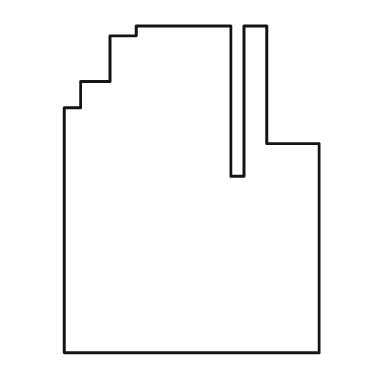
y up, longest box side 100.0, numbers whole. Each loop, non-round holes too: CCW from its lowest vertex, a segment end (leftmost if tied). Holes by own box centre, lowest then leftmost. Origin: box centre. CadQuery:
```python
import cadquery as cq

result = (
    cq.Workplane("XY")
    .moveTo(-39.0, -50.0)
    .lineTo(39.0, -50.0)
    .lineTo(39.0, 14.0)
    .lineTo(23.0, 14.0)
    .lineTo(23.0, 50.0)
    .lineTo(16.0, 50.0)
    .lineTo(16.0, 4.0)
    .lineTo(12.0, 4.0)
    .lineTo(12.0, 50.0)
    .lineTo(-17.0, 50.0)
    .lineTo(-17.0, 47.0)
    .lineTo(-25.0, 47.0)
    .lineTo(-25.0, 33.0)
    .lineTo(-34.0, 33.0)
    .lineTo(-34.0, 25.0)
    .lineTo(-39.0, 25.0)
    .close()
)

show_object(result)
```